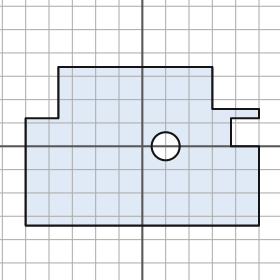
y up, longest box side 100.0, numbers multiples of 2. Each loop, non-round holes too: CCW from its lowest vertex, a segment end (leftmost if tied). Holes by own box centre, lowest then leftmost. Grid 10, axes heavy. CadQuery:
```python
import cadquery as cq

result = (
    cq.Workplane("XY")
    .moveTo(-50.0, -34.0)
    .lineTo(50.0, -34.0)
    .lineTo(50.0, 0.0)
    .lineTo(38.0, 0.0)
    .lineTo(38.0, 12.0)
    .lineTo(50.0, 12.0)
    .lineTo(50.0, 16.0)
    .lineTo(30.0, 16.0)
    .lineTo(30.0, 34.0)
    .lineTo(-36.0, 34.0)
    .lineTo(-36.0, 12.0)
    .lineTo(-50.0, 12.0)
    .close()
    .moveTo(10.0, 0.0)
    .circle(6.0)
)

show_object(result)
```